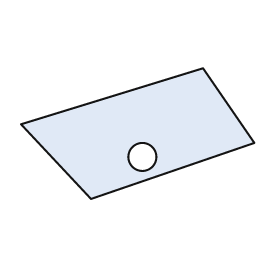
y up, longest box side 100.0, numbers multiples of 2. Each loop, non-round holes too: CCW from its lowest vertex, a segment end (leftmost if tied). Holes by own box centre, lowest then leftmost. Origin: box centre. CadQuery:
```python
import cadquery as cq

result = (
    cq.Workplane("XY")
    .moveTo(-20.0, -28.0)
    .lineTo(50.0, -4.0)
    .lineTo(28.0, 28.0)
    .lineTo(-50.0, 4.0)
    .close()
    .moveTo(2.0, -10.0)
    .circle(6.0)
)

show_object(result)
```